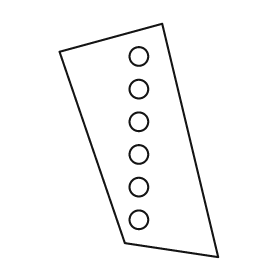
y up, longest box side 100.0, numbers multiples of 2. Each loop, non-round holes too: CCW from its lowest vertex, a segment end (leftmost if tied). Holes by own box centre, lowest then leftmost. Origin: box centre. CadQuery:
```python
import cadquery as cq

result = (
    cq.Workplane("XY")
    .moveTo(34.0, -50.0)
    .lineTo(10.0, 50.0)
    .lineTo(-34.0, 38.0)
    .lineTo(-6.0, -44.0)
    .close()
    .moveTo(0.0, -34.0)
    .circle(4.0)
    .moveTo(0.0, -20.0)
    .circle(4.0)
    .moveTo(0.0, -6.0)
    .circle(4.0)
    .moveTo(0.0, 8.0)
    .circle(4.0)
    .moveTo(0.0, 22.0)
    .circle(4.0)
    .moveTo(0.0, 36.0)
    .circle(4.0)
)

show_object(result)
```